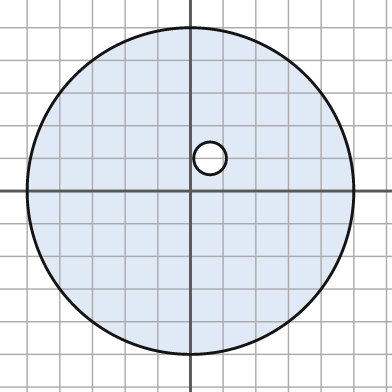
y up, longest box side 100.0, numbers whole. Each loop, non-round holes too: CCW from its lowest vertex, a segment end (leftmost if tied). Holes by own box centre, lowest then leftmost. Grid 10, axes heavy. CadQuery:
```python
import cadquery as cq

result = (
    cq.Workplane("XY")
    .moveTo(0.0, 0.0)
    .circle(50.0)
    .moveTo(6.0, 10.0)
    .circle(5.0)
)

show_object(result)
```